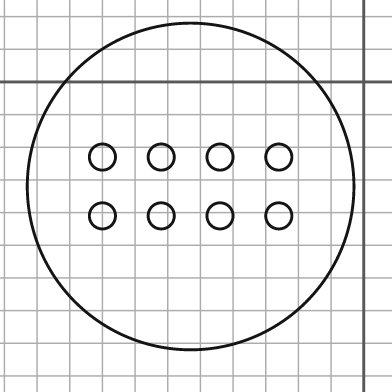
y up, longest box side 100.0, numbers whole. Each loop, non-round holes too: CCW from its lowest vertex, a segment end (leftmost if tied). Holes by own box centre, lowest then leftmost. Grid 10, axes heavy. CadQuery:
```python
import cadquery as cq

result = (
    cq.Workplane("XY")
    .moveTo(-53.0, -32.0)
    .circle(50.0)
    .moveTo(-80.0, -41.0)
    .circle(4.0)
    .moveTo(-62.0, -41.0)
    .circle(4.0)
    .moveTo(-44.0, -41.0)
    .circle(4.0)
    .moveTo(-26.0, -41.0)
    .circle(4.0)
    .moveTo(-80.0, -23.0)
    .circle(4.0)
    .moveTo(-62.0, -23.0)
    .circle(4.0)
    .moveTo(-44.0, -23.0)
    .circle(4.0)
    .moveTo(-26.0, -23.0)
    .circle(4.0)
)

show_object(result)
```